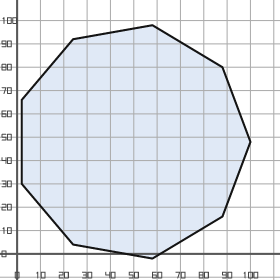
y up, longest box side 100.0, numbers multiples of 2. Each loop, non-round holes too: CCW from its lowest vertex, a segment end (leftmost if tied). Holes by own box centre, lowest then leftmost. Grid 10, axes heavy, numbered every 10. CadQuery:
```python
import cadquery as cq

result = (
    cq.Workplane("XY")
    .moveTo(58.0, -2.0)
    .lineTo(88.0, 16.0)
    .lineTo(100.0, 48.0)
    .lineTo(88.0, 80.0)
    .lineTo(58.0, 98.0)
    .lineTo(24.0, 92.0)
    .lineTo(2.0, 66.0)
    .lineTo(2.0, 30.0)
    .lineTo(24.0, 4.0)
    .close()
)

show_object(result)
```